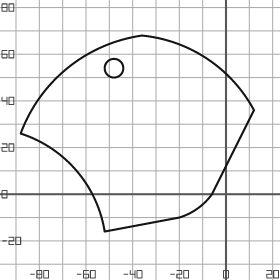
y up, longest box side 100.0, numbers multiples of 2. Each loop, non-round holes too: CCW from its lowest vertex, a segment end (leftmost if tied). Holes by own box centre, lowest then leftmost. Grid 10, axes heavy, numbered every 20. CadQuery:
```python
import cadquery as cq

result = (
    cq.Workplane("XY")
    .moveTo(-52.0, -16.0)
    .lineTo(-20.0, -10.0)
    .threePointArc((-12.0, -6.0), (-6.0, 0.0))
    .lineTo(12.0, 36.0)
    .threePointArc((-8.0, 58.0), (-36.0, 68.0))
    .threePointArc((-68.0, 54.0), (-88.0, 26.0))
    .threePointArc((-64.0, 10.0), (-52.0, -16.0))
    .close()
    .moveTo(-48.0, 54.0)
    .circle(4.0)
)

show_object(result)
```